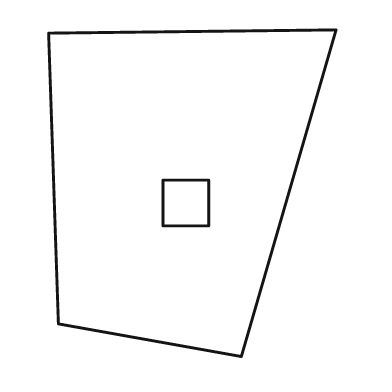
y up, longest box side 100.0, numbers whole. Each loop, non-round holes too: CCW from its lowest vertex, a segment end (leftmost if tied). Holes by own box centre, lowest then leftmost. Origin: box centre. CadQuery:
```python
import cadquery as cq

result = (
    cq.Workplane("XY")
    .moveTo(15.0, -50.0)
    .lineTo(44.0, 50.0)
    .lineTo(-44.0, 49.0)
    .lineTo(-41.0, -40.0)
    .close()
    .moveTo(-9.0, -10.0)
    .lineTo(5.0, -10.0)
    .lineTo(5.0, 4.0)
    .lineTo(-9.0, 4.0)
    .close()
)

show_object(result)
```